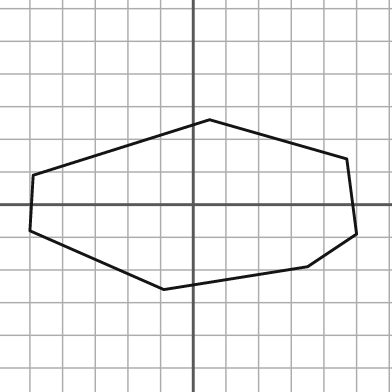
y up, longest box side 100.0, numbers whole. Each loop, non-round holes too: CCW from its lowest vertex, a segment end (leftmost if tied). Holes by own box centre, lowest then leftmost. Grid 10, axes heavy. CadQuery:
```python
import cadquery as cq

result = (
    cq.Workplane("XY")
    .moveTo(-9.0, -26.0)
    .lineTo(35.0, -19.0)
    .lineTo(50.0, -9.0)
    .lineTo(47.0, 14.0)
    .lineTo(5.0, 26.0)
    .lineTo(-49.0, 9.0)
    .lineTo(-50.0, -8.0)
    .close()
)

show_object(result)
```